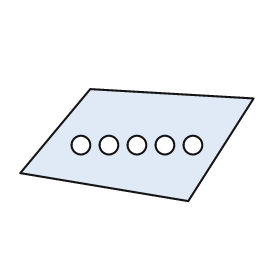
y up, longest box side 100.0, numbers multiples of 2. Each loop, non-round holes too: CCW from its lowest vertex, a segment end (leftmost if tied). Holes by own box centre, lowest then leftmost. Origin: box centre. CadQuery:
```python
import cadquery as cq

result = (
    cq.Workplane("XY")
    .moveTo(22.0, -24.0)
    .lineTo(50.0, 20.0)
    .lineTo(-20.0, 24.0)
    .lineTo(-50.0, -12.0)
    .close()
    .moveTo(-24.0, 0.0)
    .circle(4.0)
    .moveTo(-12.0, 0.0)
    .circle(4.0)
    .moveTo(0.0, 0.0)
    .circle(4.0)
    .moveTo(12.0, 0.0)
    .circle(4.0)
    .moveTo(24.0, 0.0)
    .circle(4.0)
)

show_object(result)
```